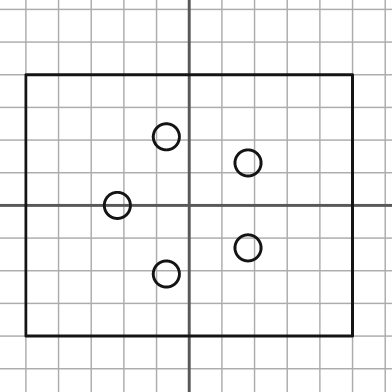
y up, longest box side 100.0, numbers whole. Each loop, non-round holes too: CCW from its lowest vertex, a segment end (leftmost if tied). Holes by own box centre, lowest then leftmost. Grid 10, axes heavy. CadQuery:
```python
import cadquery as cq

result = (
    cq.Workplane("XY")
    .moveTo(-50.0, -40.0)
    .lineTo(50.0, -40.0)
    .lineTo(50.0, 40.0)
    .lineTo(-50.0, 40.0)
    .close()
    .moveTo(-7.0, -21.0)
    .circle(4.0)
    .moveTo(18.0, -13.0)
    .circle(4.0)
    .moveTo(-22.0, 0.0)
    .circle(4.0)
    .moveTo(18.0, 13.0)
    .circle(4.0)
    .moveTo(-7.0, 21.0)
    .circle(4.0)
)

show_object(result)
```